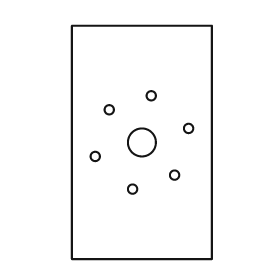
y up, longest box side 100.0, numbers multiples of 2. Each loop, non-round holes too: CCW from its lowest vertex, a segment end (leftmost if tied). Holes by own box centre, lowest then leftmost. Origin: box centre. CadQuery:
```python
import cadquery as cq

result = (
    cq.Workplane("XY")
    .moveTo(-30.0, -50.0)
    .lineTo(30.0, -50.0)
    .lineTo(30.0, 50.0)
    .lineTo(-30.0, 50.0)
    .close()
    .moveTo(-4.0, -20.0)
    .circle(2.0)
    .moveTo(14.0, -14.0)
    .circle(2.0)
    .moveTo(-20.0, -6.0)
    .circle(2.0)
    .moveTo(0.0, 0.0)
    .circle(6.0)
    .moveTo(20.0, 6.0)
    .circle(2.0)
    .moveTo(-14.0, 14.0)
    .circle(2.0)
    .moveTo(4.0, 20.0)
    .circle(2.0)
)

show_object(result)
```